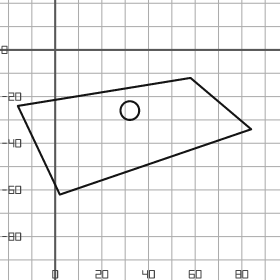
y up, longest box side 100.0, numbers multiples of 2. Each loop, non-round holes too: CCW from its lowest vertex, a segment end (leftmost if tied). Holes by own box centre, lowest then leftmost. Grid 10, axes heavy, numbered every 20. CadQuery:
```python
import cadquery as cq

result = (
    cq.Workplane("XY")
    .moveTo(2.0, -62.0)
    .lineTo(84.0, -34.0)
    .lineTo(58.0, -12.0)
    .lineTo(-16.0, -24.0)
    .close()
    .moveTo(32.0, -26.0)
    .circle(4.0)
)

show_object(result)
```